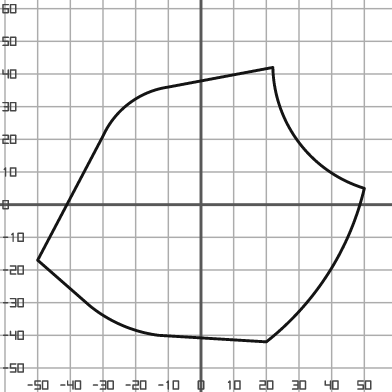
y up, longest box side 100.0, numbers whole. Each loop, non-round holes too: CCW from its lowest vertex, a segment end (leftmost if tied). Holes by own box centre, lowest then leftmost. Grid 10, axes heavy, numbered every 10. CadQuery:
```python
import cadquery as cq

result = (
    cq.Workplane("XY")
    .moveTo(20.0, -42.0)
    .threePointArc((39.0, -21.0), (50.0, 5.0))
    .threePointArc((30.0, 19.0), (22.0, 42.0))
    .lineTo(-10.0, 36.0)
    .threePointArc((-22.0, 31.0), (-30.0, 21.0))
    .lineTo(-50.0, -17.0)
    .lineTo(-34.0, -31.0)
    .threePointArc((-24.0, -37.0), (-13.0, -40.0))
    .close()
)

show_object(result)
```